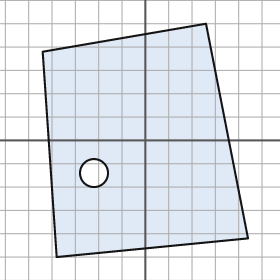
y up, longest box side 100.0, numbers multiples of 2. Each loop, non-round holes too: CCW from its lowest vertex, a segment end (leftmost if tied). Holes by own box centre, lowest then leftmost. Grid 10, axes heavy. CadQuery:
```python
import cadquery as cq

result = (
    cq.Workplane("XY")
    .moveTo(-38.0, -50.0)
    .lineTo(44.0, -42.0)
    .lineTo(26.0, 50.0)
    .lineTo(-44.0, 38.0)
    .close()
    .moveTo(-22.0, -14.0)
    .circle(6.0)
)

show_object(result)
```